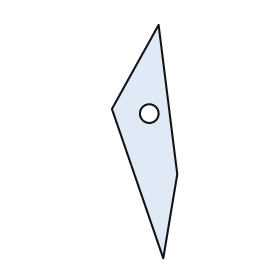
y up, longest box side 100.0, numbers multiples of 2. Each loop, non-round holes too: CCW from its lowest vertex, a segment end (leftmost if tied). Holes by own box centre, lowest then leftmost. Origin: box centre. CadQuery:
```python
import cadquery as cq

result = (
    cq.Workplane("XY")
    .moveTo(8.0, -50.0)
    .lineTo(14.0, -14.0)
    .lineTo(6.0, 50.0)
    .lineTo(-14.0, 14.0)
    .close()
    .moveTo(2.0, 12.0)
    .circle(4.0)
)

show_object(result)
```